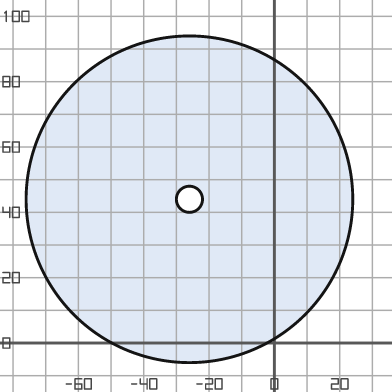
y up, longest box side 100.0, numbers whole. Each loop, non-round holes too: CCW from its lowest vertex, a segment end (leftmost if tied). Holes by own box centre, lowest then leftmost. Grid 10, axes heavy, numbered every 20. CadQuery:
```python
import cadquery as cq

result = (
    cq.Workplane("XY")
    .moveTo(-26.0, 44.0)
    .circle(50.0)
    .moveTo(-26.0, 44.0)
    .circle(4.0)
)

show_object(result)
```